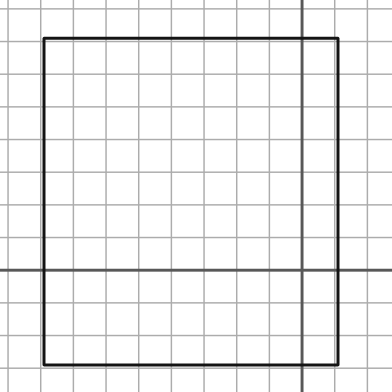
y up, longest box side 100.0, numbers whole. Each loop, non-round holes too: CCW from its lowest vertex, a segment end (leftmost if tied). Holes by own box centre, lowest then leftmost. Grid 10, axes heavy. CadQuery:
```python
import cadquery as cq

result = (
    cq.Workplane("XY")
    .moveTo(-79.0, -29.0)
    .lineTo(11.0, -29.0)
    .lineTo(11.0, 71.0)
    .lineTo(-79.0, 71.0)
    .close()
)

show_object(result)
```